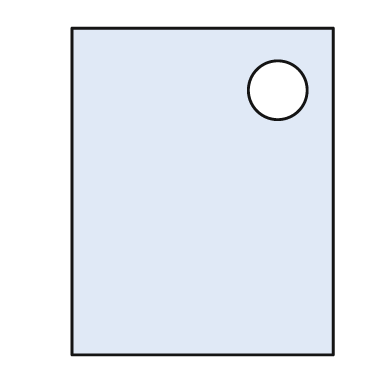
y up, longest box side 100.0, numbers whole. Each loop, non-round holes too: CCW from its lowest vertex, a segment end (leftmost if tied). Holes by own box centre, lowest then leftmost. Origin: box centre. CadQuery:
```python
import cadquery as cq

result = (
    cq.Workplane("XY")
    .moveTo(-40.0, -50.0)
    .lineTo(40.0, -50.0)
    .lineTo(40.0, 50.0)
    .lineTo(-40.0, 50.0)
    .close()
    .moveTo(23.0, 31.0)
    .circle(9.0)
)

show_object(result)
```